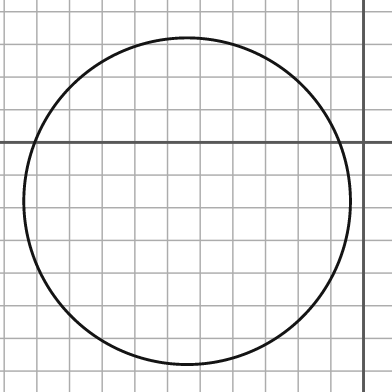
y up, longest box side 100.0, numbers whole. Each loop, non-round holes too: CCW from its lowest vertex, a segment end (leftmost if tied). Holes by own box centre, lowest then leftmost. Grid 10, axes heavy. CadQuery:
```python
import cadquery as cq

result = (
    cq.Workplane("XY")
    .moveTo(-54.0, -18.0)
    .circle(50.0)
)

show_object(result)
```